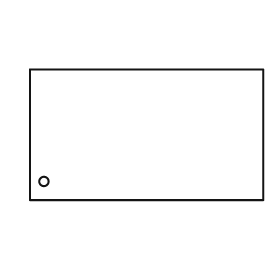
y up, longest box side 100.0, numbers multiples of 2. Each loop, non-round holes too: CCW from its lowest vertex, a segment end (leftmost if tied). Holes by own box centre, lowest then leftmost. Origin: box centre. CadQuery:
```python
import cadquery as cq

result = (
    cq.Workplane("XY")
    .moveTo(-50.0, -28.0)
    .lineTo(50.0, -28.0)
    .lineTo(50.0, 28.0)
    .lineTo(-50.0, 28.0)
    .close()
    .moveTo(-44.0, -20.0)
    .circle(2.0)
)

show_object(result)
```